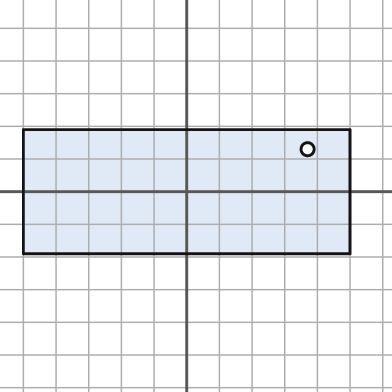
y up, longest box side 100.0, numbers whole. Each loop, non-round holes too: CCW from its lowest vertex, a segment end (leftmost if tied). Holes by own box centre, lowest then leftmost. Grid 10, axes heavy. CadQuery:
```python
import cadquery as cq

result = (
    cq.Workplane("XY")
    .moveTo(-50.0, -19.0)
    .lineTo(50.0, -19.0)
    .lineTo(50.0, 19.0)
    .lineTo(-50.0, 19.0)
    .close()
    .moveTo(37.0, 13.0)
    .circle(2.0)
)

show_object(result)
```